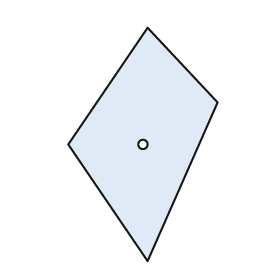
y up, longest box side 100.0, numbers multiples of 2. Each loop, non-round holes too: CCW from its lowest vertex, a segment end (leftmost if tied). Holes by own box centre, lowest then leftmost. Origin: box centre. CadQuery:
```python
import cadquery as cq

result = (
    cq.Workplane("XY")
    .moveTo(2.0, -50.0)
    .lineTo(32.0, 18.0)
    .lineTo(2.0, 50.0)
    .lineTo(-32.0, 0.0)
    .close()
    .moveTo(0.0, 0.0)
    .circle(2.0)
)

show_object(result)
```